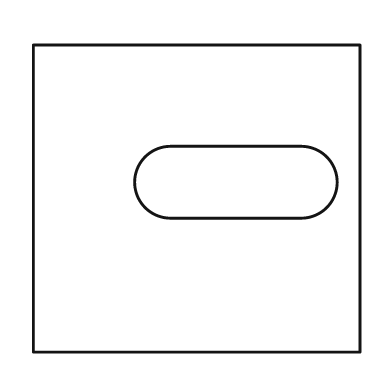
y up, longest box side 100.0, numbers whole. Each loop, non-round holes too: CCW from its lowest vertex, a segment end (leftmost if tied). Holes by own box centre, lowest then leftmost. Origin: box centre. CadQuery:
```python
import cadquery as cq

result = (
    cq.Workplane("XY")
    .moveTo(-50.0, -47.0)
    .lineTo(50.0, -47.0)
    .lineTo(50.0, 47.0)
    .lineTo(-50.0, 47.0)
    .close()
    .moveTo(-8.0, -6.0)
    .lineTo(32.0, -6.0)
    .threePointArc((43.0, 5.0), (32.0, 16.0))
    .lineTo(-8.0, 16.0)
    .threePointArc((-19.0, 5.0), (-8.0, -6.0))
    .close()
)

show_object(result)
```